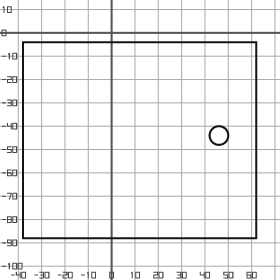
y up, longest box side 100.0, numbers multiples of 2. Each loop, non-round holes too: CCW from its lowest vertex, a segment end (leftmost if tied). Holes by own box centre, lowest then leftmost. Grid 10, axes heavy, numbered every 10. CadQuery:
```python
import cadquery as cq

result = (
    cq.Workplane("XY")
    .moveTo(-38.0, -88.0)
    .lineTo(62.0, -88.0)
    .lineTo(62.0, -4.0)
    .lineTo(-38.0, -4.0)
    .close()
    .moveTo(46.0, -44.0)
    .circle(4.0)
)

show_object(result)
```